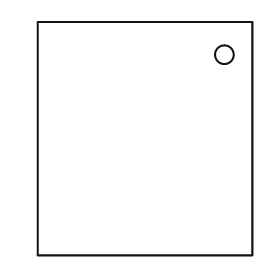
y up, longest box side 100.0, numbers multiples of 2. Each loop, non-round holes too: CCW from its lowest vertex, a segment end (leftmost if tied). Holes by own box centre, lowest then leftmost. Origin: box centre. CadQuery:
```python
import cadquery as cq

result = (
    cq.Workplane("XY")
    .moveTo(-46.0, -50.0)
    .lineTo(46.0, -50.0)
    .lineTo(46.0, 50.0)
    .lineTo(-46.0, 50.0)
    .close()
    .moveTo(34.0, 36.0)
    .circle(4.0)
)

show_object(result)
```